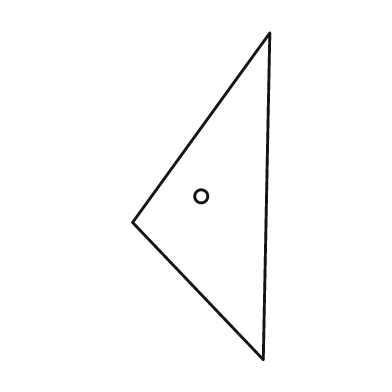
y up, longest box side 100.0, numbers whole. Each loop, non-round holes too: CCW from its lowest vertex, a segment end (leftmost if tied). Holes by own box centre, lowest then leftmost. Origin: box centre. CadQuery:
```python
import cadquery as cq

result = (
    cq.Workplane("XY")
    .moveTo(19.0, -50.0)
    .lineTo(21.0, 50.0)
    .lineTo(-21.0, -8.0)
    .close()
    .moveTo(0.0, 0.0)
    .circle(2.0)
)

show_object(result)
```